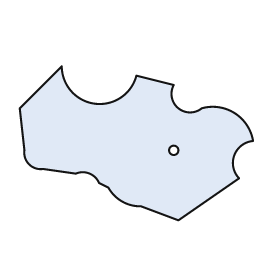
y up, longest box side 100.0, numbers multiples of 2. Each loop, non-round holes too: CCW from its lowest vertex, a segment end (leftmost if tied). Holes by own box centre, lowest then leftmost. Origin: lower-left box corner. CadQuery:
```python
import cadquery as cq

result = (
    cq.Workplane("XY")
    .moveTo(68.0, 0.0)
    .lineTo(94.0, 18.0)
    .threePointArc((92.0, 28.0), (100.0, 34.0))
    .threePointArc((92.0, 46.0), (78.0, 48.0))
    .threePointArc((68.0, 48.0), (66.0, 58.0))
    .lineTo(50.0, 62.0)
    .threePointArc((32.0, 50.0), (18.0, 66.0))
    .lineTo(0.0, 48.0)
    .lineTo(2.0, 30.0)
    .threePointArc((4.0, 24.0), (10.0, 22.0))
    .lineTo(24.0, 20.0)
    .threePointArc((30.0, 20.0), (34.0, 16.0))
    .lineTo(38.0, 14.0)
    .threePointArc((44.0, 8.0), (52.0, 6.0))
    .close()
    .moveTo(66.0, 30.0)
    .circle(2.0)
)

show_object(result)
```